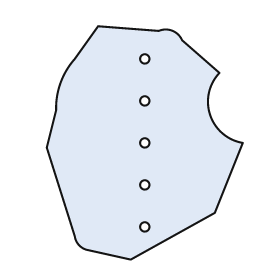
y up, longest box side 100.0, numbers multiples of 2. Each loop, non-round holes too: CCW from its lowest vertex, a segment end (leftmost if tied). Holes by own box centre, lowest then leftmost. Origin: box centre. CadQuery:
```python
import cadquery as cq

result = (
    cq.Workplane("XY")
    .moveTo(-6.0, -50.0)
    .lineTo(30.0, -30.0)
    .lineTo(42.0, 0.0)
    .threePointArc((28.0, 12.0), (32.0, 30.0))
    .lineTo(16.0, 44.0)
    .threePointArc((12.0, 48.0), (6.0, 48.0))
    .lineTo(-20.0, 50.0)
    .lineTo(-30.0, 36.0)
    .threePointArc((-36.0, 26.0), (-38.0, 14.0))
    .lineTo(-42.0, -2.0)
    .lineTo(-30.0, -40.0)
    .threePointArc((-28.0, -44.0), (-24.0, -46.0))
    .close()
    .moveTo(0.0, -36.0)
    .circle(2.0)
    .moveTo(0.0, -18.0)
    .circle(2.0)
    .moveTo(0.0, 0.0)
    .circle(2.0)
    .moveTo(0.0, 18.0)
    .circle(2.0)
    .moveTo(0.0, 36.0)
    .circle(2.0)
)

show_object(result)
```